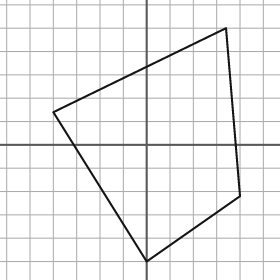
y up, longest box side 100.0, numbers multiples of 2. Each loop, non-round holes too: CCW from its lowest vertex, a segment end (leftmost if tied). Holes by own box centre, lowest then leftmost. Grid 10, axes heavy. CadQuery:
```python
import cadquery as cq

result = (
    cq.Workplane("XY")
    .moveTo(0.0, -50.0)
    .lineTo(40.0, -22.0)
    .lineTo(34.0, 50.0)
    .lineTo(-40.0, 14.0)
    .close()
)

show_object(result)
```